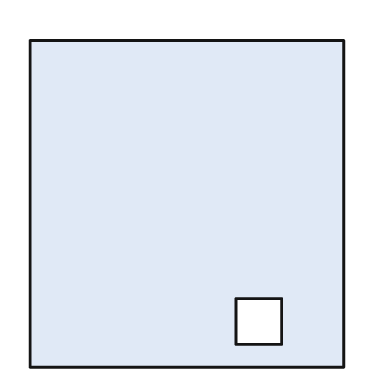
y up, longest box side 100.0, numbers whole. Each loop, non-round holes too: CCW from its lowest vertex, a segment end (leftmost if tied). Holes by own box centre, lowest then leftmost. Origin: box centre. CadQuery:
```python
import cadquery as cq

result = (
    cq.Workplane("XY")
    .moveTo(-48.0, -50.0)
    .lineTo(48.0, -50.0)
    .lineTo(48.0, 50.0)
    .lineTo(-48.0, 50.0)
    .close()
    .moveTo(15.0, -43.0)
    .lineTo(29.0, -43.0)
    .lineTo(29.0, -29.0)
    .lineTo(15.0, -29.0)
    .close()
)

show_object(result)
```